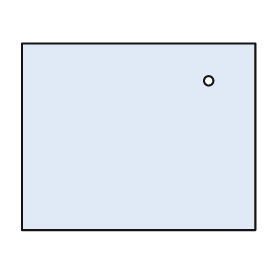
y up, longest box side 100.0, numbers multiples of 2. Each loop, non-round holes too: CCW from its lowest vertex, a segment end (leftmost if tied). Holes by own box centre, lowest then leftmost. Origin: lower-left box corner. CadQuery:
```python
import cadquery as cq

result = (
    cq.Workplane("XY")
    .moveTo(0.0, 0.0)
    .lineTo(100.0, 0.0)
    .lineTo(100.0, 80.0)
    .lineTo(0.0, 80.0)
    .close()
    .moveTo(80.0, 64.0)
    .circle(2.0)
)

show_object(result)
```